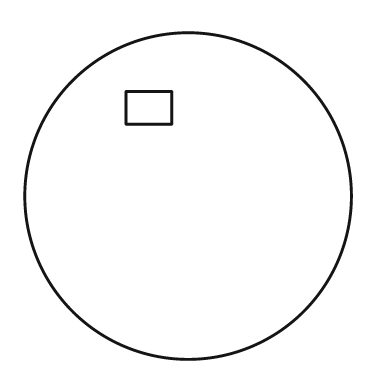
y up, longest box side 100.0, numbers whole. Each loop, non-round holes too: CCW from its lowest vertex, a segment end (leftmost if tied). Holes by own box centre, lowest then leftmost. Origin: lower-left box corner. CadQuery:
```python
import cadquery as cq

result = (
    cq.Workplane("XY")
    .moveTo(50.0, 50.0)
    .circle(50.0)
    .moveTo(31.0, 72.0)
    .lineTo(45.0, 72.0)
    .lineTo(45.0, 82.0)
    .lineTo(31.0, 82.0)
    .close()
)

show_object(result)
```